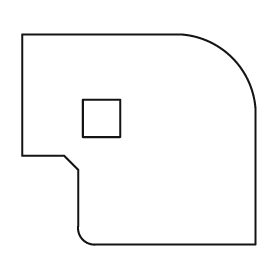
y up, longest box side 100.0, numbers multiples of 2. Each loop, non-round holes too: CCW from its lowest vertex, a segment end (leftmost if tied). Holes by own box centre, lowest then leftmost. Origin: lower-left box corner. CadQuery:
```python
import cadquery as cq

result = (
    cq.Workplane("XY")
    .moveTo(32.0, 0.0)
    .lineTo(100.0, 0.0)
    .lineTo(100.0, 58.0)
    .threePointArc((90.0, 80.0), (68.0, 90.0))
    .lineTo(0.0, 90.0)
    .lineTo(0.0, 38.0)
    .lineTo(18.0, 38.0)
    .lineTo(24.0, 32.0)
    .lineTo(24.0, 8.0)
    .threePointArc((26.0, 2.0), (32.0, 0.0))
    .close()
    .moveTo(26.0, 46.0)
    .lineTo(42.0, 46.0)
    .lineTo(42.0, 62.0)
    .lineTo(26.0, 62.0)
    .close()
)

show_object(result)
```